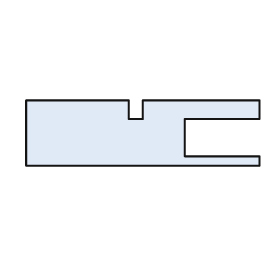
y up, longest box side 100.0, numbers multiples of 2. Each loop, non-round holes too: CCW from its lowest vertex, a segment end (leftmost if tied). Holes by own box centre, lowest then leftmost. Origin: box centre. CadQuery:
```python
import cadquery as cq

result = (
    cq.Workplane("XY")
    .moveTo(-50.0, -14.0)
    .lineTo(50.0, -14.0)
    .lineTo(50.0, -10.0)
    .lineTo(18.0, -10.0)
    .lineTo(18.0, 6.0)
    .lineTo(50.0, 6.0)
    .lineTo(50.0, 14.0)
    .lineTo(0.0, 14.0)
    .lineTo(0.0, 6.0)
    .lineTo(-6.0, 6.0)
    .lineTo(-6.0, 14.0)
    .lineTo(-50.0, 14.0)
    .close()
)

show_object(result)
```